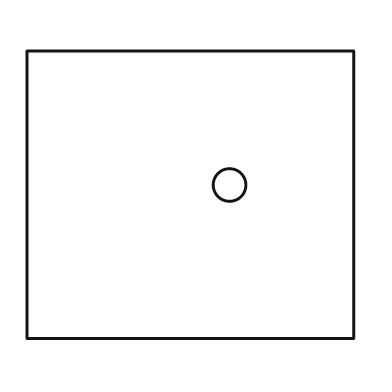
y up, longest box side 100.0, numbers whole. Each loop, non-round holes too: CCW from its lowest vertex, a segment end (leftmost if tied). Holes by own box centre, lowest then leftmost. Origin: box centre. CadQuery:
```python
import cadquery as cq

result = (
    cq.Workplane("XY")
    .moveTo(-50.0, -44.0)
    .lineTo(50.0, -44.0)
    .lineTo(50.0, 44.0)
    .lineTo(-50.0, 44.0)
    .close()
    .moveTo(12.0, 3.0)
    .circle(5.0)
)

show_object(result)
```